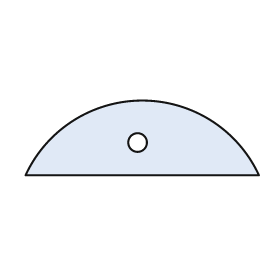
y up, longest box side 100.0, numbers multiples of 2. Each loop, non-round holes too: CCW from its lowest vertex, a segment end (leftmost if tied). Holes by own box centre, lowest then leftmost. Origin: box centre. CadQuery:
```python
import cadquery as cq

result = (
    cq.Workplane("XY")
    .moveTo(-50.0, -16.0)
    .lineTo(50.0, -16.0)
    .threePointArc((0.0, 16.0), (-50.0, -16.0))
    .close()
    .moveTo(-2.0, -2.0)
    .circle(4.0)
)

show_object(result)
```